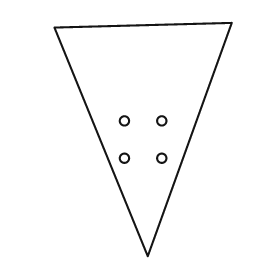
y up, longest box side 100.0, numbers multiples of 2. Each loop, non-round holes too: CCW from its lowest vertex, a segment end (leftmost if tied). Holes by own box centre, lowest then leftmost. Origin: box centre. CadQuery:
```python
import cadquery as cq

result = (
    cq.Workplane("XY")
    .moveTo(2.0, -50.0)
    .lineTo(38.0, 50.0)
    .lineTo(-38.0, 48.0)
    .close()
    .moveTo(-8.0, -8.0)
    .circle(2.0)
    .moveTo(8.0, -8.0)
    .circle(2.0)
    .moveTo(-8.0, 8.0)
    .circle(2.0)
    .moveTo(8.0, 8.0)
    .circle(2.0)
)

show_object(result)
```